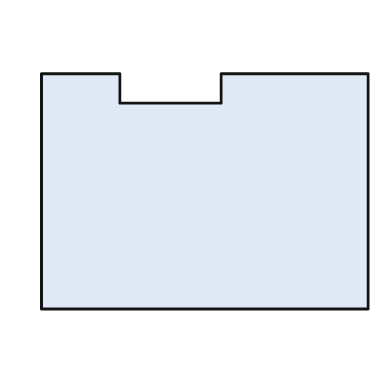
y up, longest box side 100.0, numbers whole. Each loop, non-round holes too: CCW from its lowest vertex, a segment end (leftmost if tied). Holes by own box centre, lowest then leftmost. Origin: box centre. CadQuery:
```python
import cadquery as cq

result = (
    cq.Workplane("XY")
    .moveTo(-50.0, -36.0)
    .lineTo(50.0, -36.0)
    .lineTo(50.0, 36.0)
    .lineTo(5.0, 36.0)
    .lineTo(5.0, 27.0)
    .lineTo(-26.0, 27.0)
    .lineTo(-26.0, 36.0)
    .lineTo(-50.0, 36.0)
    .close()
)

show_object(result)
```